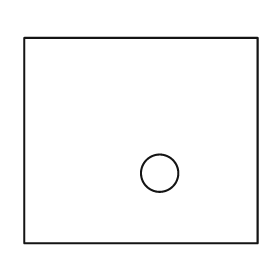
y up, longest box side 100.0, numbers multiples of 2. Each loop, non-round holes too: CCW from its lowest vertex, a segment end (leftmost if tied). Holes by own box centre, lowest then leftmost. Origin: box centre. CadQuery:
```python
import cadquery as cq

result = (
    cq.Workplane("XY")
    .moveTo(-50.0, -44.0)
    .lineTo(50.0, -44.0)
    .lineTo(50.0, 44.0)
    .lineTo(-50.0, 44.0)
    .close()
    .moveTo(8.0, -14.0)
    .circle(8.0)
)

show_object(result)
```